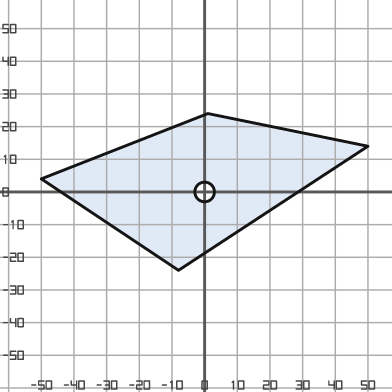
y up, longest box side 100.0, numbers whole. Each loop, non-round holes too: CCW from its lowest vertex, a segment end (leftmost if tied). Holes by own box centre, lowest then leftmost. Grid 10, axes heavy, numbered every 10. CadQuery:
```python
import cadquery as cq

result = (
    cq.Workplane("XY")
    .moveTo(-8.0, -24.0)
    .lineTo(50.0, 14.0)
    .lineTo(1.0, 24.0)
    .lineTo(-50.0, 4.0)
    .close()
    .moveTo(0.0, 0.0)
    .circle(3.0)
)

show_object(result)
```